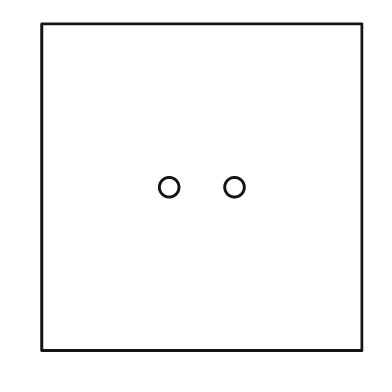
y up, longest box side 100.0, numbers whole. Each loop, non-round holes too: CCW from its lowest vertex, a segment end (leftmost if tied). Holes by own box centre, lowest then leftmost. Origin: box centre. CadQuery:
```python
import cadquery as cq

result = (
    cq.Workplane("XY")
    .moveTo(-49.0, -50.0)
    .lineTo(49.0, -50.0)
    .lineTo(49.0, 50.0)
    .lineTo(-49.0, 50.0)
    .close()
    .moveTo(-10.0, 0.0)
    .circle(3.0)
    .moveTo(10.0, 0.0)
    .circle(3.0)
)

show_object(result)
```